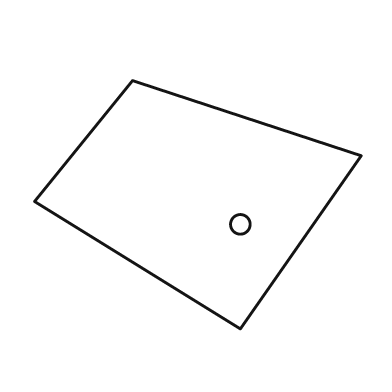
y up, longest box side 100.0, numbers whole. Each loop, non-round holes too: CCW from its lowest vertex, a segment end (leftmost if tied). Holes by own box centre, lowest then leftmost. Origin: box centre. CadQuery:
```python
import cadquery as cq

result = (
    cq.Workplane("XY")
    .moveTo(13.0, -38.0)
    .lineTo(50.0, 15.0)
    .lineTo(-20.0, 38.0)
    .lineTo(-50.0, 1.0)
    .close()
    .moveTo(13.0, -6.0)
    .circle(3.0)
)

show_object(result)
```